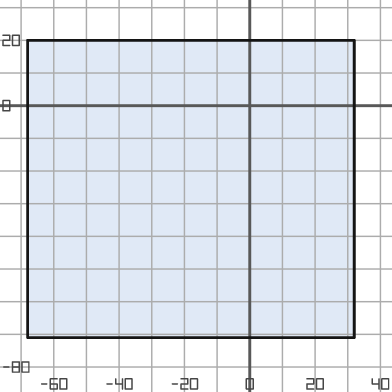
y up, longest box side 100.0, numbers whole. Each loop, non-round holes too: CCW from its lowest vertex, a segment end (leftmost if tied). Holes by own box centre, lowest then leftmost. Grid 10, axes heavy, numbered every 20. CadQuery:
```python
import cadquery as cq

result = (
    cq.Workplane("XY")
    .moveTo(-68.0, -71.0)
    .lineTo(32.0, -71.0)
    .lineTo(32.0, 20.0)
    .lineTo(-68.0, 20.0)
    .close()
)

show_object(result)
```